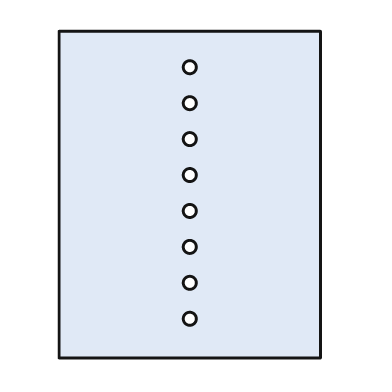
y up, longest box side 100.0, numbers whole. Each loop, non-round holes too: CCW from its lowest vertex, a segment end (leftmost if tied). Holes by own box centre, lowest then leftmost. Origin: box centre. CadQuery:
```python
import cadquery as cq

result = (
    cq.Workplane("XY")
    .moveTo(-40.0, -50.0)
    .lineTo(40.0, -50.0)
    .lineTo(40.0, 50.0)
    .lineTo(-40.0, 50.0)
    .close()
    .moveTo(0.0, -38.0)
    .circle(2.0)
    .moveTo(0.0, -27.0)
    .circle(2.0)
    .moveTo(0.0, -16.0)
    .circle(2.0)
    .moveTo(0.0, -5.0)
    .circle(2.0)
    .moveTo(0.0, 6.0)
    .circle(2.0)
    .moveTo(0.0, 17.0)
    .circle(2.0)
    .moveTo(0.0, 28.0)
    .circle(2.0)
    .moveTo(0.0, 39.0)
    .circle(2.0)
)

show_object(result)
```